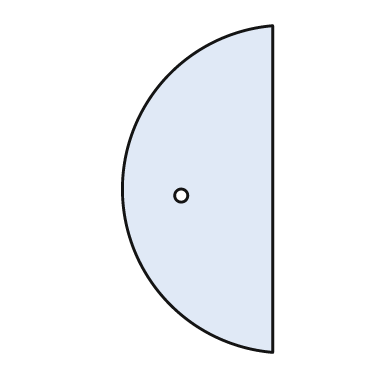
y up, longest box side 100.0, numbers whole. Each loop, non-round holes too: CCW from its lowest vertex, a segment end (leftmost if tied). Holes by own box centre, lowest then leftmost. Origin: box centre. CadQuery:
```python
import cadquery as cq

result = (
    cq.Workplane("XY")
    .moveTo(23.0, -50.0)
    .lineTo(23.0, 50.0)
    .threePointArc((-23.0, 0.0), (23.0, -50.0))
    .close()
    .moveTo(-5.0, -2.0)
    .circle(2.0)
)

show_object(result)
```